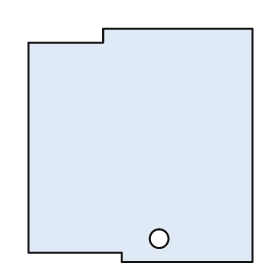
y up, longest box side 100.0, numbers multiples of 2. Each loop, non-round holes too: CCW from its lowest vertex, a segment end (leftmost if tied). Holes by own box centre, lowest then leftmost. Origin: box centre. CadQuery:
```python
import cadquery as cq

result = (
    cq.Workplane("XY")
    .moveTo(-8.0, -50.0)
    .lineTo(48.0, -50.0)
    .lineTo(48.0, 50.0)
    .lineTo(-16.0, 50.0)
    .lineTo(-16.0, 44.0)
    .lineTo(-48.0, 44.0)
    .lineTo(-48.0, -46.0)
    .lineTo(-8.0, -46.0)
    .close()
    .moveTo(8.0, -40.0)
    .circle(4.0)
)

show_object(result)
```